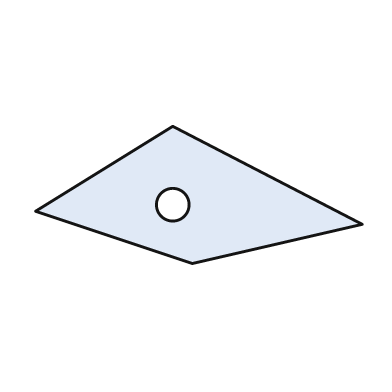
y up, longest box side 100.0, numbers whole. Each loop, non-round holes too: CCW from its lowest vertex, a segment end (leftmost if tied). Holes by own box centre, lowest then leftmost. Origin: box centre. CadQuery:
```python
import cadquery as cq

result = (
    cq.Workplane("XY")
    .moveTo(-2.0, -21.0)
    .lineTo(50.0, -9.0)
    .lineTo(-8.0, 21.0)
    .lineTo(-50.0, -5.0)
    .close()
    .moveTo(-8.0, -3.0)
    .circle(5.0)
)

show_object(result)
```